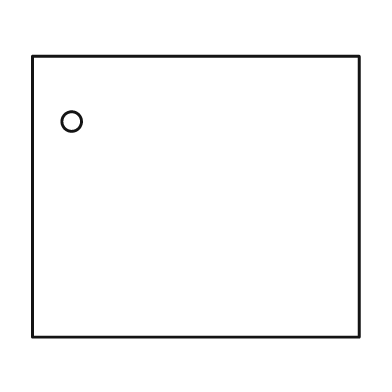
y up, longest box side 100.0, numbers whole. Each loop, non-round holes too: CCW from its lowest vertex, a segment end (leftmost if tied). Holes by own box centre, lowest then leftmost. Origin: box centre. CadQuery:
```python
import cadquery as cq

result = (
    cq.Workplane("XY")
    .moveTo(-50.0, -43.0)
    .lineTo(50.0, -43.0)
    .lineTo(50.0, 43.0)
    .lineTo(-50.0, 43.0)
    .close()
    .moveTo(-38.0, 23.0)
    .circle(3.0)
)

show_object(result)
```